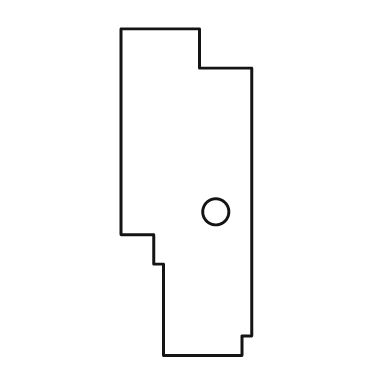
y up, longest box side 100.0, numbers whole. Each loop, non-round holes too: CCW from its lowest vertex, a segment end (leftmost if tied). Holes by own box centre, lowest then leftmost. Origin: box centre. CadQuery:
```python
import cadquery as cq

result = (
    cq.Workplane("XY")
    .moveTo(-7.0, -50.0)
    .lineTo(17.0, -50.0)
    .lineTo(17.0, -44.0)
    .lineTo(20.0, -44.0)
    .lineTo(20.0, 38.0)
    .lineTo(4.0, 38.0)
    .lineTo(4.0, 50.0)
    .lineTo(-20.0, 50.0)
    .lineTo(-20.0, -13.0)
    .lineTo(-10.0, -13.0)
    .lineTo(-10.0, -22.0)
    .lineTo(-7.0, -22.0)
    .close()
    .moveTo(9.0, -6.0)
    .circle(4.0)
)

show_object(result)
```